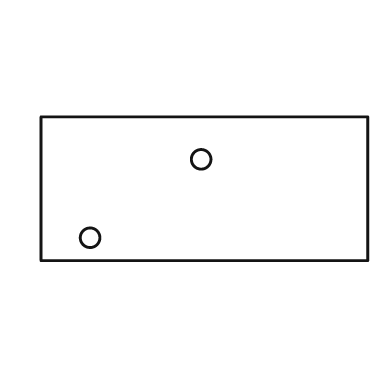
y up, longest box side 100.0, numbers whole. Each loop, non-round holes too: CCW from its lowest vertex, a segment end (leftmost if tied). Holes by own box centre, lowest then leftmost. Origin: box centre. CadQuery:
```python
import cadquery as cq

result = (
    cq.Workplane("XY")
    .moveTo(-50.0, -22.0)
    .lineTo(50.0, -22.0)
    .lineTo(50.0, 22.0)
    .lineTo(-50.0, 22.0)
    .close()
    .moveTo(-35.0, -15.0)
    .circle(3.0)
    .moveTo(-1.0, 9.0)
    .circle(3.0)
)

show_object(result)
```